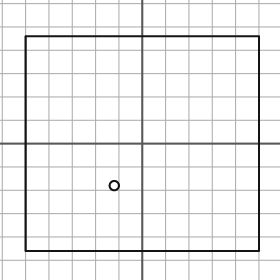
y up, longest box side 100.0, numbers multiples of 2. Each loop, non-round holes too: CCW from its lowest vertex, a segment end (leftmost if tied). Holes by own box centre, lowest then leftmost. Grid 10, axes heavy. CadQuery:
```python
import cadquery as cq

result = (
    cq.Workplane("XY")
    .moveTo(-50.0, -46.0)
    .lineTo(50.0, -46.0)
    .lineTo(50.0, 46.0)
    .lineTo(-50.0, 46.0)
    .close()
    .moveTo(-12.0, -18.0)
    .circle(2.0)
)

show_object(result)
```